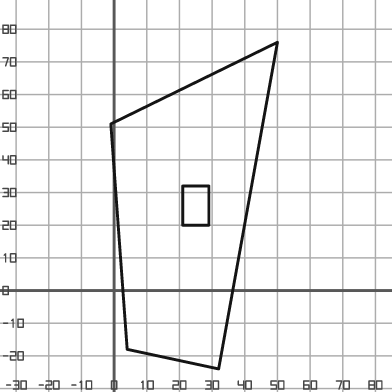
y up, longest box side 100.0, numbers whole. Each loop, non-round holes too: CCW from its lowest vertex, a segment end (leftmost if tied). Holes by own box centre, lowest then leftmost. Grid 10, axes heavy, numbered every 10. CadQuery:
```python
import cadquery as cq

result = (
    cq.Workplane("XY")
    .moveTo(32.0, -24.0)
    .lineTo(50.0, 76.0)
    .lineTo(-1.0, 51.0)
    .lineTo(4.0, -18.0)
    .close()
    .moveTo(21.0, 20.0)
    .lineTo(29.0, 20.0)
    .lineTo(29.0, 32.0)
    .lineTo(21.0, 32.0)
    .close()
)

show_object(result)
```